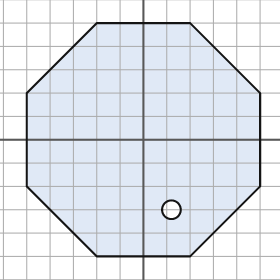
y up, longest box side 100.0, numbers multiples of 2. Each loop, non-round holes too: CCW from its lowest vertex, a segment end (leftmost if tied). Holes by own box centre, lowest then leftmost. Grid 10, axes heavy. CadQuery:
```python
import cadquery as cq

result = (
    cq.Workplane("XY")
    .moveTo(-20.0, -50.0)
    .lineTo(20.0, -50.0)
    .lineTo(50.0, -20.0)
    .lineTo(50.0, 20.0)
    .lineTo(20.0, 50.0)
    .lineTo(-20.0, 50.0)
    .lineTo(-50.0, 20.0)
    .lineTo(-50.0, -20.0)
    .close()
    .moveTo(12.0, -30.0)
    .circle(4.0)
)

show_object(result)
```